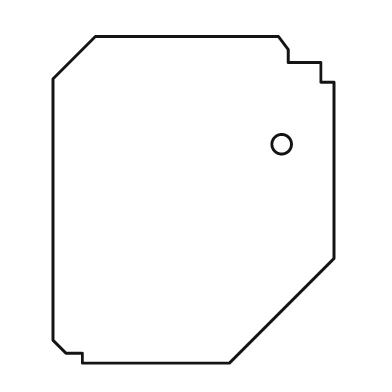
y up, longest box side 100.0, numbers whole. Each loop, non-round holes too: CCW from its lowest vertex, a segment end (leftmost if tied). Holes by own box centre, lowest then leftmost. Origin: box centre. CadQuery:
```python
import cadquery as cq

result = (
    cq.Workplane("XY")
    .moveTo(-34.0, -50.0)
    .lineTo(11.0, -50.0)
    .lineTo(43.0, -18.0)
    .lineTo(43.0, 36.0)
    .lineTo(39.0, 36.0)
    .lineTo(39.0, 42.0)
    .lineTo(29.0, 42.0)
    .lineTo(29.0, 46.0)
    .lineTo(26.0, 50.0)
    .lineTo(-30.0, 50.0)
    .lineTo(-43.0, 37.0)
    .lineTo(-43.0, -43.0)
    .lineTo(-39.0, -47.0)
    .lineTo(-34.0, -47.0)
    .close()
    .moveTo(27.0, 17.0)
    .circle(3.0)
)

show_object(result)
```